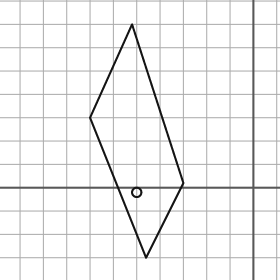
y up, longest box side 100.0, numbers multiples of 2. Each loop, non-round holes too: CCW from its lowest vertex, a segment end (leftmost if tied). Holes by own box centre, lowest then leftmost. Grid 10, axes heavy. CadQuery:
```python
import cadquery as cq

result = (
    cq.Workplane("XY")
    .moveTo(-46.0, -30.0)
    .lineTo(-30.0, 2.0)
    .lineTo(-52.0, 70.0)
    .lineTo(-70.0, 30.0)
    .close()
    .moveTo(-50.0, -2.0)
    .circle(2.0)
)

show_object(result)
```